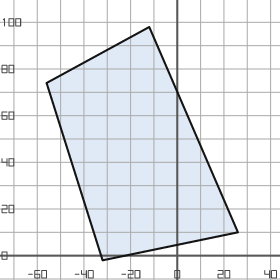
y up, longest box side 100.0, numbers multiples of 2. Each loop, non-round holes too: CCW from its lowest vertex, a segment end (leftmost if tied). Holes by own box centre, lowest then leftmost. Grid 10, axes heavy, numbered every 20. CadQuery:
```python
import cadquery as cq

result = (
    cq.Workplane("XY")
    .moveTo(-32.0, -2.0)
    .lineTo(26.0, 10.0)
    .lineTo(-12.0, 98.0)
    .lineTo(-56.0, 74.0)
    .close()
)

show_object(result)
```